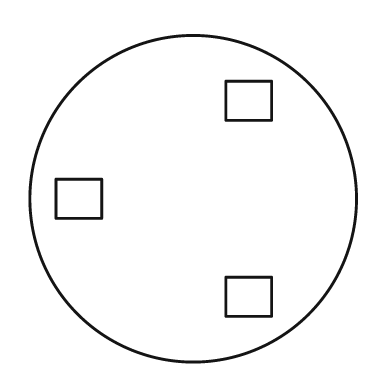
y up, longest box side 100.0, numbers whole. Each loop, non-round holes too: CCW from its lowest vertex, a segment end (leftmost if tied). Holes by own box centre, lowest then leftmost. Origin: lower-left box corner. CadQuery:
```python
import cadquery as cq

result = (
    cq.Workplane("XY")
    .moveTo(50.0, 50.0)
    .circle(50.0)
    .moveTo(60.0, 14.0)
    .lineTo(74.0, 14.0)
    .lineTo(74.0, 26.0)
    .lineTo(60.0, 26.0)
    .close()
    .moveTo(8.0, 44.0)
    .lineTo(22.0, 44.0)
    .lineTo(22.0, 56.0)
    .lineTo(8.0, 56.0)
    .close()
    .moveTo(60.0, 74.0)
    .lineTo(74.0, 74.0)
    .lineTo(74.0, 86.0)
    .lineTo(60.0, 86.0)
    .close()
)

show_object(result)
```